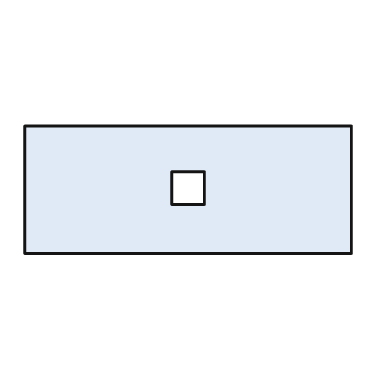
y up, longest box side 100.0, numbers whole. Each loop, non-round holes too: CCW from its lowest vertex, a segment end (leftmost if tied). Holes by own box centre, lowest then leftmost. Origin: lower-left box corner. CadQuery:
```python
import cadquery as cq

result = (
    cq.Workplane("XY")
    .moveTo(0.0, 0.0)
    .lineTo(100.0, 0.0)
    .lineTo(100.0, 39.0)
    .lineTo(0.0, 39.0)
    .close()
    .moveTo(45.0, 15.0)
    .lineTo(55.0, 15.0)
    .lineTo(55.0, 25.0)
    .lineTo(45.0, 25.0)
    .close()
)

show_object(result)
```